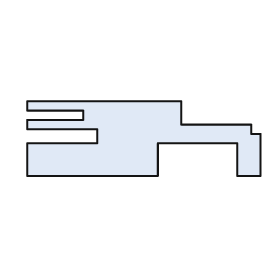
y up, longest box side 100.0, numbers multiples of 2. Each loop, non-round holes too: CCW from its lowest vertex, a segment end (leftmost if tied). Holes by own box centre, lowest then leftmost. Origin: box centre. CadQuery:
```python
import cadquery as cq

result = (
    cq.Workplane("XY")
    .moveTo(-50.0, -16.0)
    .lineTo(6.0, -16.0)
    .lineTo(6.0, -2.0)
    .lineTo(40.0, -2.0)
    .lineTo(40.0, -16.0)
    .lineTo(50.0, -16.0)
    .lineTo(50.0, 2.0)
    .lineTo(46.0, 2.0)
    .lineTo(46.0, 6.0)
    .lineTo(16.0, 6.0)
    .lineTo(16.0, 16.0)
    .lineTo(-50.0, 16.0)
    .lineTo(-50.0, 12.0)
    .lineTo(-26.0, 12.0)
    .lineTo(-26.0, 8.0)
    .lineTo(-50.0, 8.0)
    .lineTo(-50.0, 4.0)
    .lineTo(-20.0, 4.0)
    .lineTo(-20.0, -2.0)
    .lineTo(-50.0, -2.0)
    .close()
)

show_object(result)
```